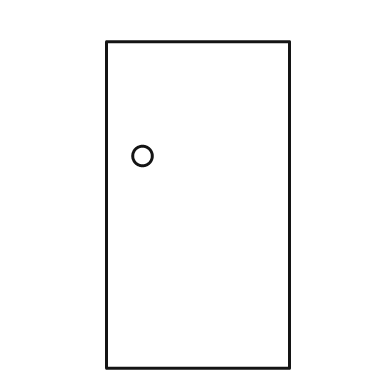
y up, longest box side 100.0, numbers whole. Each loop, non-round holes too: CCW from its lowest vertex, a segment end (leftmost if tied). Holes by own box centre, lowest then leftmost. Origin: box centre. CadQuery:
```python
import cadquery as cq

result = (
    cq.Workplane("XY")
    .moveTo(-28.0, -50.0)
    .lineTo(28.0, -50.0)
    .lineTo(28.0, 50.0)
    .lineTo(-28.0, 50.0)
    .close()
    .moveTo(-17.0, 15.0)
    .circle(3.0)
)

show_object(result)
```